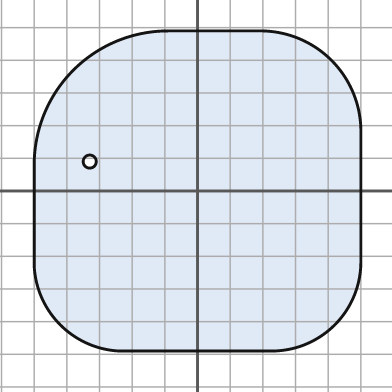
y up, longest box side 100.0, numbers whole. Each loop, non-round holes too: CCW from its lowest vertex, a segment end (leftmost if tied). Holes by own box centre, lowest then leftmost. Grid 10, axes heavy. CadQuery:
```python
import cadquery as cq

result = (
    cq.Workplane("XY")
    .moveTo(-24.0, -49.0)
    .lineTo(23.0, -49.0)
    .threePointArc((42.0, -41.0), (50.0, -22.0))
    .lineTo(50.0, 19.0)
    .threePointArc((41.0, 40.0), (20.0, 49.0))
    .lineTo(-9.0, 49.0)
    .threePointArc((-38.0, 37.0), (-50.0, 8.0))
    .lineTo(-50.0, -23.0)
    .threePointArc((-42.0, -41.0), (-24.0, -49.0))
    .close()
    .moveTo(-33.0, 9.0)
    .circle(2.0)
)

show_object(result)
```